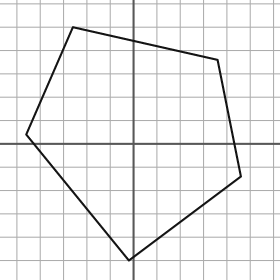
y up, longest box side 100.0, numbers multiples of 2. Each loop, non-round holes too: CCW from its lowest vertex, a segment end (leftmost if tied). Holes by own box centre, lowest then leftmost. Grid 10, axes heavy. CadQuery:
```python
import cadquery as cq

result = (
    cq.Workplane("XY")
    .moveTo(-2.0, -50.0)
    .lineTo(46.0, -14.0)
    .lineTo(36.0, 36.0)
    .lineTo(-26.0, 50.0)
    .lineTo(-46.0, 4.0)
    .close()
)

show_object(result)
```